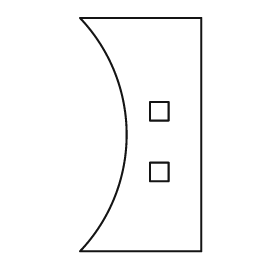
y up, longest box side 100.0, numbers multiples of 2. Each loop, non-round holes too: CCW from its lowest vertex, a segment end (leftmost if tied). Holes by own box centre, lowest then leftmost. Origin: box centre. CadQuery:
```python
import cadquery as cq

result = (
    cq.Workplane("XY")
    .moveTo(-26.0, -50.0)
    .lineTo(26.0, -50.0)
    .lineTo(26.0, 50.0)
    .lineTo(-26.0, 50.0)
    .threePointArc((-6.0, 0.0), (-26.0, -50.0))
    .close()
    .moveTo(4.0, -20.0)
    .lineTo(12.0, -20.0)
    .lineTo(12.0, -12.0)
    .lineTo(4.0, -12.0)
    .close()
    .moveTo(4.0, 6.0)
    .lineTo(12.0, 6.0)
    .lineTo(12.0, 14.0)
    .lineTo(4.0, 14.0)
    .close()
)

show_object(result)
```